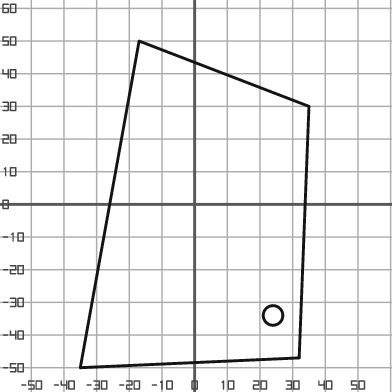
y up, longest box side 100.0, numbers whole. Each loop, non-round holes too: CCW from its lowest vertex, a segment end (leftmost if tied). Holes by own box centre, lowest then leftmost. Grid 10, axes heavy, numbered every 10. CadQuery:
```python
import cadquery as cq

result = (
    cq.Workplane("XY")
    .moveTo(-35.0, -50.0)
    .lineTo(32.0, -47.0)
    .lineTo(35.0, 30.0)
    .lineTo(-17.0, 50.0)
    .close()
    .moveTo(24.0, -34.0)
    .circle(3.0)
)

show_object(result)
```